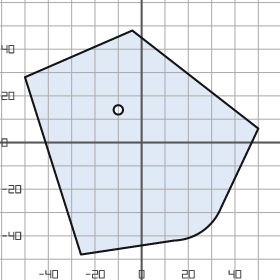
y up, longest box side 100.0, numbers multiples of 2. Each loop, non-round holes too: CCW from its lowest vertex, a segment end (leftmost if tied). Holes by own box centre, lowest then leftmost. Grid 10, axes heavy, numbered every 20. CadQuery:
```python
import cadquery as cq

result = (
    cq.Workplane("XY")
    .moveTo(-26.0, -48.0)
    .lineTo(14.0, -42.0)
    .threePointArc((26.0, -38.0), (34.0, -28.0))
    .lineTo(50.0, 6.0)
    .lineTo(-4.0, 48.0)
    .lineTo(-50.0, 28.0)
    .close()
    .moveTo(-10.0, 14.0)
    .circle(2.0)
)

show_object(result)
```